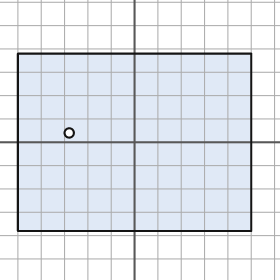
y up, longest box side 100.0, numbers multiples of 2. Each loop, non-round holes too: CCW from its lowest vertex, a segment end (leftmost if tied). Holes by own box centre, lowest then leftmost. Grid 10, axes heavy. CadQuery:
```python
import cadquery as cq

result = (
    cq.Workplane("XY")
    .moveTo(-50.0, -38.0)
    .lineTo(50.0, -38.0)
    .lineTo(50.0, 38.0)
    .lineTo(-50.0, 38.0)
    .close()
    .moveTo(-28.0, 4.0)
    .circle(2.0)
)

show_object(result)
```